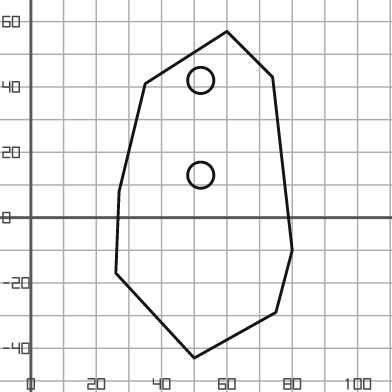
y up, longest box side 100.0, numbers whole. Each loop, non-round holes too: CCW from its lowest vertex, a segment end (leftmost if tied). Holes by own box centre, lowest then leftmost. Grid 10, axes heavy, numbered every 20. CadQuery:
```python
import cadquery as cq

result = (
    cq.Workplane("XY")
    .moveTo(50.0, -43.0)
    .lineTo(75.0, -29.0)
    .lineTo(80.0, -10.0)
    .lineTo(74.0, 43.0)
    .lineTo(60.0, 57.0)
    .lineTo(35.0, 41.0)
    .lineTo(27.0, 8.0)
    .lineTo(26.0, -17.0)
    .close()
    .moveTo(52.0, 13.0)
    .circle(4.0)
    .moveTo(52.0, 42.0)
    .circle(4.0)
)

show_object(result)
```